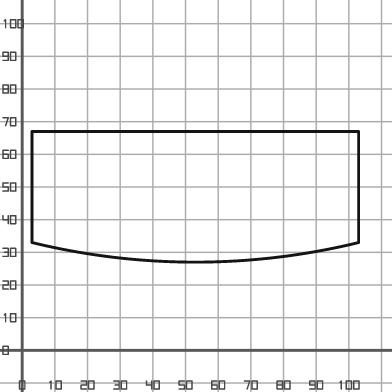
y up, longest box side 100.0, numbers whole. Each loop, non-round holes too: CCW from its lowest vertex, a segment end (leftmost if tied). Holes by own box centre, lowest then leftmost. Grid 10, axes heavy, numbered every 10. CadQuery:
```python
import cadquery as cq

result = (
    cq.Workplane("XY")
    .moveTo(3.0, 33.0)
    .threePointArc((53.0, 27.0), (103.0, 33.0))
    .lineTo(103.0, 67.0)
    .lineTo(3.0, 67.0)
    .close()
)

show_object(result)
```